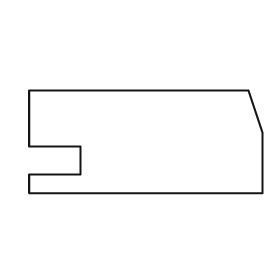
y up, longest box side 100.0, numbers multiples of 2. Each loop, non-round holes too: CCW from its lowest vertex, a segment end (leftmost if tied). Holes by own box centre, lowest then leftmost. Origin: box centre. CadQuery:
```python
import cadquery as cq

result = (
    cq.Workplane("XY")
    .moveTo(-50.0, -22.0)
    .lineTo(50.0, -22.0)
    .lineTo(50.0, 4.0)
    .lineTo(44.0, 22.0)
    .lineTo(-50.0, 22.0)
    .lineTo(-50.0, -2.0)
    .lineTo(-28.0, -2.0)
    .lineTo(-28.0, -14.0)
    .lineTo(-50.0, -14.0)
    .close()
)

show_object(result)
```